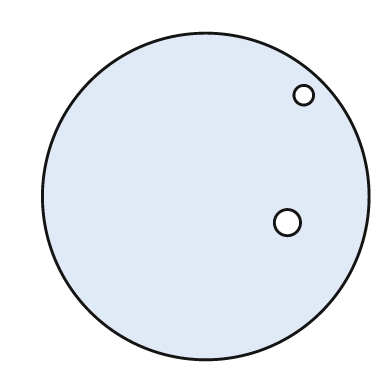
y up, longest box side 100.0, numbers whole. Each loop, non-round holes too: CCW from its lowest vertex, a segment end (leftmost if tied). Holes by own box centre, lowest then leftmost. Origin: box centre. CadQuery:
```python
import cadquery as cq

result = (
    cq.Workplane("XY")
    .moveTo(0.0, 0.0)
    .circle(50.0)
    .moveTo(25.0, -8.0)
    .circle(4.0)
    .moveTo(30.0, 31.0)
    .circle(3.0)
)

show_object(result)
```